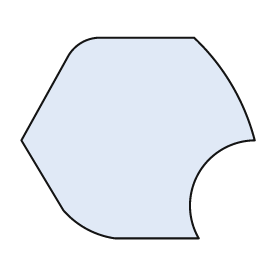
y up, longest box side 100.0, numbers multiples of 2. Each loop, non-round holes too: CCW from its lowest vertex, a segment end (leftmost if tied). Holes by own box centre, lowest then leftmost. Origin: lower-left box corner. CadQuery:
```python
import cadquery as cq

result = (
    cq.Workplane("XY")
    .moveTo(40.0, 0.0)
    .lineTo(76.0, 0.0)
    .threePointArc((76.0, 28.0), (100.0, 42.0))
    .threePointArc((90.0, 66.0), (74.0, 86.0))
    .lineTo(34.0, 86.0)
    .threePointArc((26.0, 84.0), (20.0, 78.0))
    .lineTo(0.0, 42.0)
    .lineTo(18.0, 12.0)
    .threePointArc((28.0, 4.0), (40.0, 0.0))
    .close()
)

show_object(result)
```